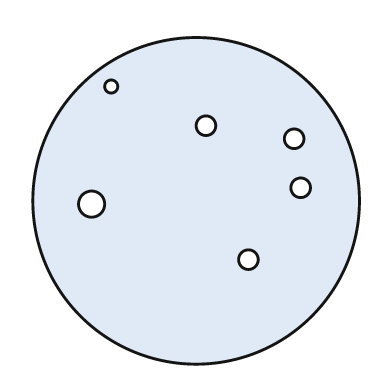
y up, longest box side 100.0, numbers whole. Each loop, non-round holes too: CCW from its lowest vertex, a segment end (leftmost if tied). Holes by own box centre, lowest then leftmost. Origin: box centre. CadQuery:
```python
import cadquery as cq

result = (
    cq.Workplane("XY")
    .moveTo(0.0, 0.0)
    .circle(50.0)
    .moveTo(16.0, -18.0)
    .circle(3.0)
    .moveTo(-32.0, -1.0)
    .circle(4.0)
    .moveTo(32.0, 4.0)
    .circle(3.0)
    .moveTo(30.0, 19.0)
    .circle(3.0)
    .moveTo(3.0, 23.0)
    .circle(3.0)
    .moveTo(-26.0, 35.0)
    .circle(2.0)
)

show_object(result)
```